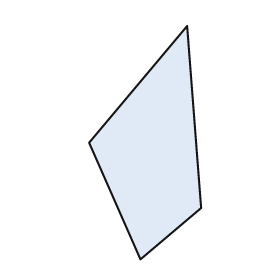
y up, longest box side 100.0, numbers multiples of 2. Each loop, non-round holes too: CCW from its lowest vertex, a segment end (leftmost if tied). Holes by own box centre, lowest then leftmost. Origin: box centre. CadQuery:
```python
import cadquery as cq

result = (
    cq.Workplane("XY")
    .moveTo(-2.0, -50.0)
    .lineTo(24.0, -28.0)
    .lineTo(18.0, 50.0)
    .lineTo(-24.0, 0.0)
    .close()
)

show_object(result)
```